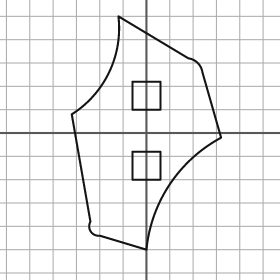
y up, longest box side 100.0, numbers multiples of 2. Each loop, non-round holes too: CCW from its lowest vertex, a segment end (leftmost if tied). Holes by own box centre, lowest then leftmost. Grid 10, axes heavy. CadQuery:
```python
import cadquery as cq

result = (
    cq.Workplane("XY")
    .moveTo(0.0, -50.0)
    .threePointArc((10.0, -22.0), (32.0, -2.0))
    .lineTo(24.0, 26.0)
    .threePointArc((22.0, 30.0), (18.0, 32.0))
    .lineTo(-12.0, 50.0)
    .threePointArc((-16.0, 26.0), (-32.0, 8.0))
    .lineTo(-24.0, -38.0)
    .threePointArc((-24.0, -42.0), (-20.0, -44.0))
    .close()
    .moveTo(-6.0, -20.0)
    .lineTo(6.0, -20.0)
    .lineTo(6.0, -8.0)
    .lineTo(-6.0, -8.0)
    .close()
    .moveTo(-6.0, 10.0)
    .lineTo(6.0, 10.0)
    .lineTo(6.0, 22.0)
    .lineTo(-6.0, 22.0)
    .close()
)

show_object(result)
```